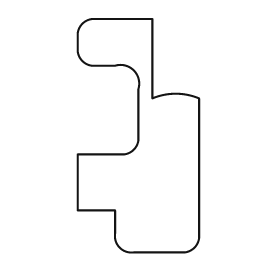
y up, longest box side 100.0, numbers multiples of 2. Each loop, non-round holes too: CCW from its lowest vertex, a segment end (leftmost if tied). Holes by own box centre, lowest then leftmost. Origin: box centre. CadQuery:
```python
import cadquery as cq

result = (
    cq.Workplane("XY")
    .moveTo(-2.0, -50.0)
    .lineTo(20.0, -50.0)
    .threePointArc((24.0, -48.0), (26.0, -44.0))
    .lineTo(26.0, 16.0)
    .threePointArc((16.0, 18.0), (6.0, 16.0))
    .lineTo(6.0, 50.0)
    .lineTo(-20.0, 50.0)
    .threePointArc((-24.0, 48.0), (-26.0, 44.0))
    .lineTo(-26.0, 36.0)
    .threePointArc((-24.0, 32.0), (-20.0, 30.0))
    .lineTo(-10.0, 30.0)
    .threePointArc((-2.0, 28.0), (0.0, 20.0))
    .lineTo(0.0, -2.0)
    .threePointArc((-2.0, -6.0), (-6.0, -8.0))
    .lineTo(-26.0, -8.0)
    .lineTo(-26.0, -32.0)
    .lineTo(-10.0, -32.0)
    .lineTo(-10.0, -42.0)
    .threePointArc((-8.0, -48.0), (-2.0, -50.0))
    .close()
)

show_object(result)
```